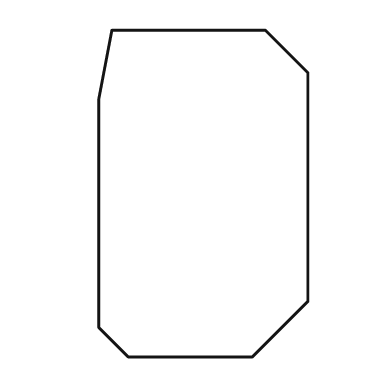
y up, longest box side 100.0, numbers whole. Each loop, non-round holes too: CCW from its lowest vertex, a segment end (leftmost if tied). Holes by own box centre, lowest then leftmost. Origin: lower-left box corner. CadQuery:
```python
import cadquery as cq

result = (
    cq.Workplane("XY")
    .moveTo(9.0, 0.0)
    .lineTo(47.0, 0.0)
    .lineTo(64.0, 17.0)
    .lineTo(64.0, 87.0)
    .lineTo(51.0, 100.0)
    .lineTo(4.0, 100.0)
    .lineTo(0.0, 79.0)
    .lineTo(0.0, 9.0)
    .close()
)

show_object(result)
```